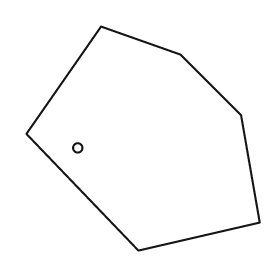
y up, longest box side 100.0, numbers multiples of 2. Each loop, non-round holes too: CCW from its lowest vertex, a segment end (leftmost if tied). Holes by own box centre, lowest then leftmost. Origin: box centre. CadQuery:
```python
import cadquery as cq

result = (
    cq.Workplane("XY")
    .moveTo(-2.0, -48.0)
    .lineTo(50.0, -36.0)
    .lineTo(42.0, 10.0)
    .lineTo(16.0, 36.0)
    .lineTo(-18.0, 48.0)
    .lineTo(-50.0, 2.0)
    .close()
    .moveTo(-28.0, -4.0)
    .circle(2.0)
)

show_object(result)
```